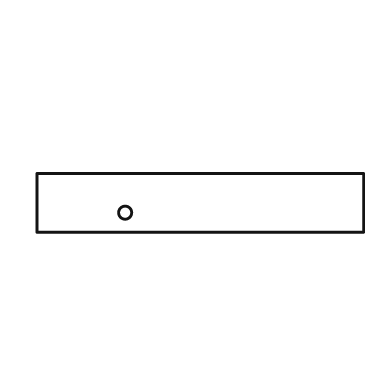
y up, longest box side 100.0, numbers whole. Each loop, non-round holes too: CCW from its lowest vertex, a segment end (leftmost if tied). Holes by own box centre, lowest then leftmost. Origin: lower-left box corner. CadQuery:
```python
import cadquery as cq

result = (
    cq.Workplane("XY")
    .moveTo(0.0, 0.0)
    .lineTo(100.0, 0.0)
    .lineTo(100.0, 18.0)
    .lineTo(0.0, 18.0)
    .close()
    .moveTo(27.0, 6.0)
    .circle(2.0)
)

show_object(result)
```